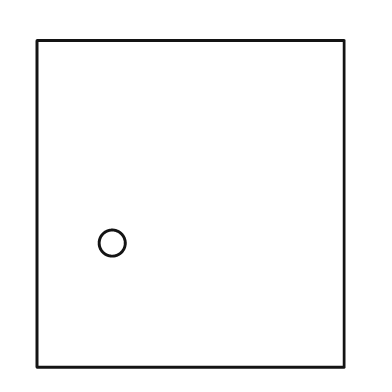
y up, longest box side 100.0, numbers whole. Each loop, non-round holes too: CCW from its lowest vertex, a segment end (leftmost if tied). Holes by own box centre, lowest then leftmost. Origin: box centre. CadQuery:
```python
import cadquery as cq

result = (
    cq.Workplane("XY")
    .moveTo(-47.0, -50.0)
    .lineTo(47.0, -50.0)
    .lineTo(47.0, 50.0)
    .lineTo(-47.0, 50.0)
    .close()
    .moveTo(-24.0, -12.0)
    .circle(4.0)
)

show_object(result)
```